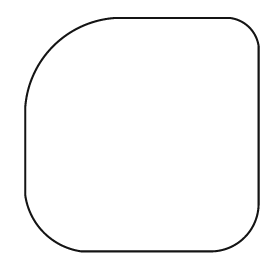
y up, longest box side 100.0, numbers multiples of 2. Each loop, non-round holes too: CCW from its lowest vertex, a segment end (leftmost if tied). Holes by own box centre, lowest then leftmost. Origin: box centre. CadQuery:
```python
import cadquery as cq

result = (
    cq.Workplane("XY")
    .moveTo(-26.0, -50.0)
    .lineTo(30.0, -50.0)
    .threePointArc((44.0, -44.0), (50.0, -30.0))
    .lineTo(50.0, 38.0)
    .threePointArc((46.0, 46.0), (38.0, 50.0))
    .lineTo(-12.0, 50.0)
    .threePointArc((-38.0, 38.0), (-50.0, 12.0))
    .lineTo(-50.0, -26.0)
    .threePointArc((-42.0, -42.0), (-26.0, -50.0))
    .close()
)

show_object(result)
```